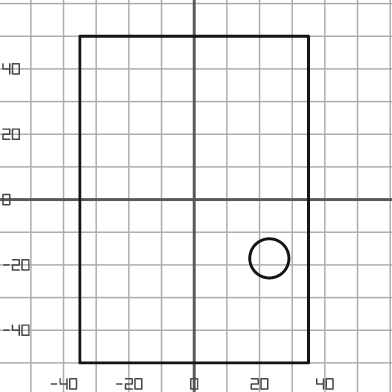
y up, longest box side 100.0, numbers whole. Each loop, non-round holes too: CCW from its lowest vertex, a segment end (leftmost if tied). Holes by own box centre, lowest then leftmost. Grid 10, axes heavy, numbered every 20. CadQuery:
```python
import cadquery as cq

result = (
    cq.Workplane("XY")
    .moveTo(-35.0, -50.0)
    .lineTo(35.0, -50.0)
    .lineTo(35.0, 50.0)
    .lineTo(-35.0, 50.0)
    .close()
    .moveTo(23.0, -18.0)
    .circle(6.0)
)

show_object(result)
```